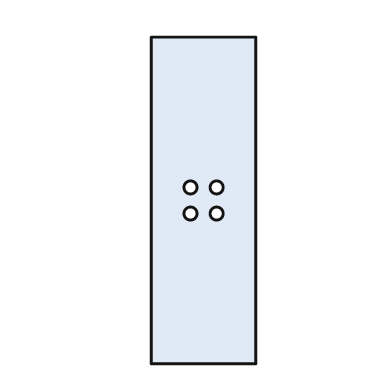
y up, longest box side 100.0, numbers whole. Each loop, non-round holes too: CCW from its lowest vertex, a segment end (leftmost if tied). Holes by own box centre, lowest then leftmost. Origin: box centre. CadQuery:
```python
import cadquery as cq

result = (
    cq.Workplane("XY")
    .moveTo(-16.0, -50.0)
    .lineTo(16.0, -50.0)
    .lineTo(16.0, 50.0)
    .lineTo(-16.0, 50.0)
    .close()
    .moveTo(-4.0, -4.0)
    .circle(2.0)
    .moveTo(4.0, -4.0)
    .circle(2.0)
    .moveTo(-4.0, 4.0)
    .circle(2.0)
    .moveTo(4.0, 4.0)
    .circle(2.0)
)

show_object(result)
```